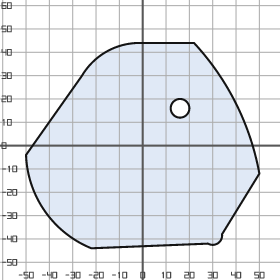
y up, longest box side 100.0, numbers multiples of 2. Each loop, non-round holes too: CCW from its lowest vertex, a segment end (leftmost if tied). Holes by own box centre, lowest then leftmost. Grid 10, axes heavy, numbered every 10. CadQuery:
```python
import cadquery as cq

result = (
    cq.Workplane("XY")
    .moveTo(-22.0, -44.0)
    .lineTo(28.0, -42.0)
    .threePointArc((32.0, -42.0), (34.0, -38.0))
    .lineTo(50.0, -12.0)
    .threePointArc((40.0, 18.0), (22.0, 44.0))
    .lineTo(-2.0, 44.0)
    .threePointArc((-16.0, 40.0), (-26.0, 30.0))
    .lineTo(-50.0, -4.0)
    .threePointArc((-42.0, -28.0), (-22.0, -44.0))
    .close()
    .moveTo(16.0, 16.0)
    .circle(4.0)
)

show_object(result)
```